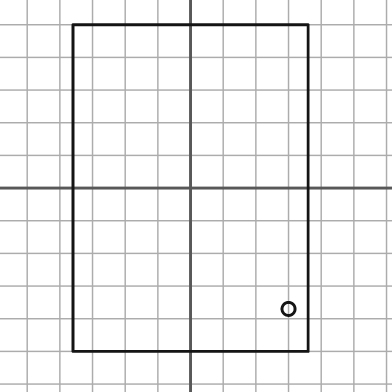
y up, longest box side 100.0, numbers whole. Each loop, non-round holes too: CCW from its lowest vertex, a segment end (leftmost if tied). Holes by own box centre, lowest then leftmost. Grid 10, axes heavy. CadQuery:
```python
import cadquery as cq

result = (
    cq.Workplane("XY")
    .moveTo(-36.0, -50.0)
    .lineTo(36.0, -50.0)
    .lineTo(36.0, 50.0)
    .lineTo(-36.0, 50.0)
    .close()
    .moveTo(30.0, -37.0)
    .circle(2.0)
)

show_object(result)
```